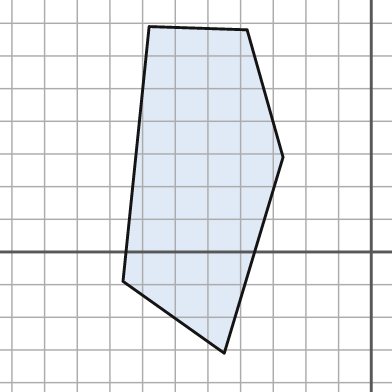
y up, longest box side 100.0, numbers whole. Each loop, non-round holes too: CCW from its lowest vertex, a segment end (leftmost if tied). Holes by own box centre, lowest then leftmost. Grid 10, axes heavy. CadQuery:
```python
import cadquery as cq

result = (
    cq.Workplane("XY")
    .moveTo(-45.0, -31.0)
    .lineTo(-27.0, 29.0)
    .lineTo(-38.0, 68.0)
    .lineTo(-68.0, 69.0)
    .lineTo(-76.0, -9.0)
    .close()
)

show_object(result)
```